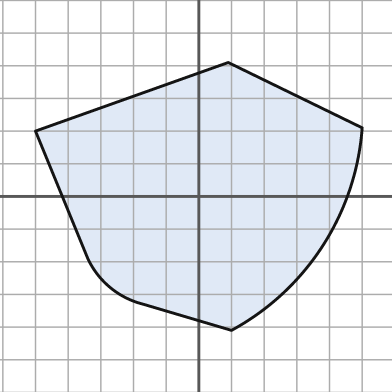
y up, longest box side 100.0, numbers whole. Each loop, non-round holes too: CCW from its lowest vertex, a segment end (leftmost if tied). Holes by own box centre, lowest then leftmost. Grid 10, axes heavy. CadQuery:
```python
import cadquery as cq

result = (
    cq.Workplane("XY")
    .moveTo(10.0, -41.0)
    .threePointArc((38.0, -15.0), (50.0, 21.0))
    .lineTo(9.0, 41.0)
    .lineTo(-50.0, 20.0)
    .lineTo(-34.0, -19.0)
    .threePointArc((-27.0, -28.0), (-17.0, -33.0))
    .close()
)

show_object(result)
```